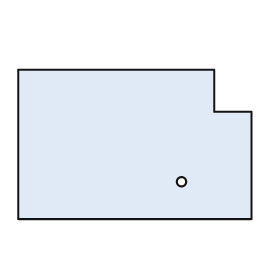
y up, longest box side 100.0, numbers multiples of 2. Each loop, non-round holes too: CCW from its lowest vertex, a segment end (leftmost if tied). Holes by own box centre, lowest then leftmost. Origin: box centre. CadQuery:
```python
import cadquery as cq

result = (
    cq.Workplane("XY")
    .moveTo(-50.0, -32.0)
    .lineTo(50.0, -32.0)
    .lineTo(50.0, 14.0)
    .lineTo(34.0, 14.0)
    .lineTo(34.0, 32.0)
    .lineTo(-50.0, 32.0)
    .close()
    .moveTo(20.0, -16.0)
    .circle(2.0)
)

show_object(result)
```